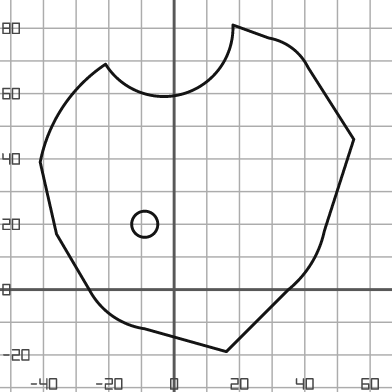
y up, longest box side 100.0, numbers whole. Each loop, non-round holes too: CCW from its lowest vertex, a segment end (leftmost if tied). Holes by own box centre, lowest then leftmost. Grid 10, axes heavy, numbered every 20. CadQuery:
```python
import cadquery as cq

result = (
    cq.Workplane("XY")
    .moveTo(16.0, -19.0)
    .lineTo(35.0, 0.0)
    .threePointArc((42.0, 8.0), (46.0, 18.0))
    .lineTo(55.0, 46.0)
    .lineTo(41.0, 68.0)
    .threePointArc((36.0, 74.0), (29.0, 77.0))
    .lineTo(18.0, 81.0)
    .threePointArc((3.0, 60.0), (-21.0, 69.0))
    .threePointArc((-34.0, 56.0), (-41.0, 39.0))
    .lineTo(-36.0, 17.0)
    .lineTo(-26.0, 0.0)
    .threePointArc((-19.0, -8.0), (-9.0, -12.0))
    .close()
    .moveTo(-9.0, 20.0)
    .circle(4.0)
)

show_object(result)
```